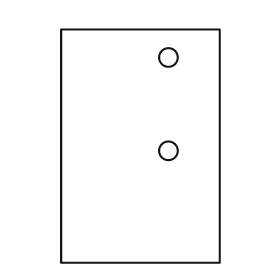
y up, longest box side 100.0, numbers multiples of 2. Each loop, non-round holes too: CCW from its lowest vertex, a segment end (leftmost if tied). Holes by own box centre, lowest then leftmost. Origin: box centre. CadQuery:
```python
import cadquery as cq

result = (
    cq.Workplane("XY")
    .moveTo(-34.0, -50.0)
    .lineTo(34.0, -50.0)
    .lineTo(34.0, 50.0)
    .lineTo(-34.0, 50.0)
    .close()
    .moveTo(12.0, -2.0)
    .circle(4.0)
    .moveTo(12.0, 38.0)
    .circle(4.0)
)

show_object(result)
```